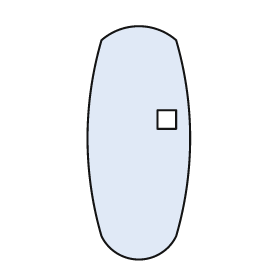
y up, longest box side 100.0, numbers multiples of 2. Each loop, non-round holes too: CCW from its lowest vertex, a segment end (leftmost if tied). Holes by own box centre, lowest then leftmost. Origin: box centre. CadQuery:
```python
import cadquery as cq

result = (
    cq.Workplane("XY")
    .moveTo(-16.0, -40.0)
    .threePointArc((0.0, -50.0), (16.0, -40.0))
    .threePointArc((22.0, 2.0), (16.0, 44.0))
    .threePointArc((0.0, 50.0), (-16.0, 44.0))
    .threePointArc((-22.0, 2.0), (-16.0, -40.0))
    .close()
    .moveTo(8.0, 6.0)
    .lineTo(16.0, 6.0)
    .lineTo(16.0, 14.0)
    .lineTo(8.0, 14.0)
    .close()
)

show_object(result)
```